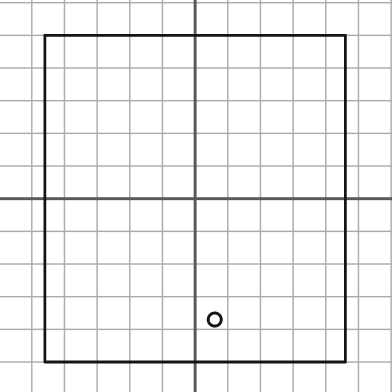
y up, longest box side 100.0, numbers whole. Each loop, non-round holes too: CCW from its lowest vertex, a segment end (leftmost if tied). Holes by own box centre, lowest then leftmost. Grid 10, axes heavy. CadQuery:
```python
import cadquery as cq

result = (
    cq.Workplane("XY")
    .moveTo(-46.0, -50.0)
    .lineTo(46.0, -50.0)
    .lineTo(46.0, 50.0)
    .lineTo(-46.0, 50.0)
    .close()
    .moveTo(6.0, -37.0)
    .circle(2.0)
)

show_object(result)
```